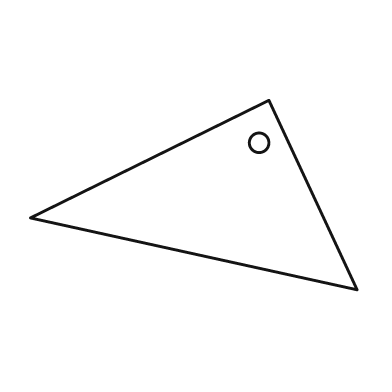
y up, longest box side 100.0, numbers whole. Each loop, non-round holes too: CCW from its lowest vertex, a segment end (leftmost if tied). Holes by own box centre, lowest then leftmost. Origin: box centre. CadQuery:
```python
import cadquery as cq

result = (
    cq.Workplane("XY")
    .moveTo(50.0, -29.0)
    .lineTo(23.0, 29.0)
    .lineTo(-50.0, -7.0)
    .close()
    .moveTo(20.0, 16.0)
    .circle(3.0)
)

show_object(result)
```